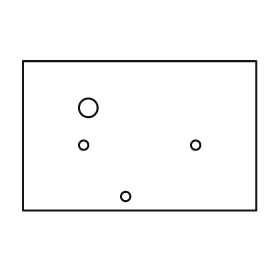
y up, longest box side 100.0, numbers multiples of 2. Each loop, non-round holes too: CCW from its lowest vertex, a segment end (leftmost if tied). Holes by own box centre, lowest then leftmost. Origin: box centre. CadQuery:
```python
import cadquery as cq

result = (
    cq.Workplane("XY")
    .moveTo(-50.0, -32.0)
    .lineTo(50.0, -32.0)
    .lineTo(50.0, 32.0)
    .lineTo(-50.0, 32.0)
    .close()
    .moveTo(-6.0, -26.0)
    .circle(2.0)
    .moveTo(-24.0, -4.0)
    .circle(2.0)
    .moveTo(24.0, -4.0)
    .circle(2.0)
    .moveTo(-22.0, 12.0)
    .circle(4.0)
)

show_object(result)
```